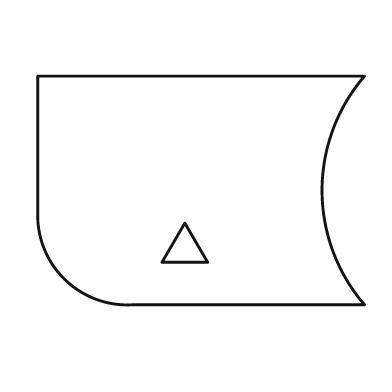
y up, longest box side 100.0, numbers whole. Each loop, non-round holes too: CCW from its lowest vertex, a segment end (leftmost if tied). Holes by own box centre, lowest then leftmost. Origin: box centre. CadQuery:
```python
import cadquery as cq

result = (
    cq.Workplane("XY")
    .moveTo(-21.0, -35.0)
    .lineTo(50.0, -35.0)
    .threePointArc((37.0, 0.0), (50.0, 35.0))
    .lineTo(-50.0, 35.0)
    .lineTo(-50.0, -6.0)
    .threePointArc((-42.0, -27.0), (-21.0, -35.0))
    .close()
    .moveTo(-12.0, -22.0)
    .lineTo(2.0, -22.0)
    .lineTo(-5.0, -10.0)
    .close()
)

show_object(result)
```